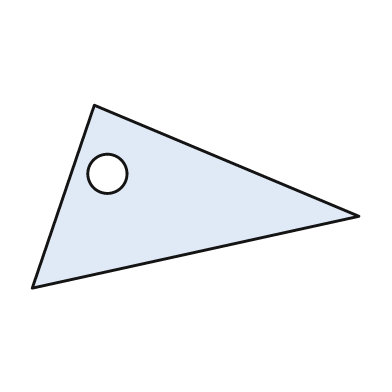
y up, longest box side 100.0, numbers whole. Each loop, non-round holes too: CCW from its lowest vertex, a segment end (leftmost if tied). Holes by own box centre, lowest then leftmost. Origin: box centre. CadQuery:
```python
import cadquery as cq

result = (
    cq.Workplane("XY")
    .moveTo(-50.0, -28.0)
    .lineTo(50.0, -6.0)
    .lineTo(-31.0, 28.0)
    .close()
    .moveTo(-27.0, 7.0)
    .circle(6.0)
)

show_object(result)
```